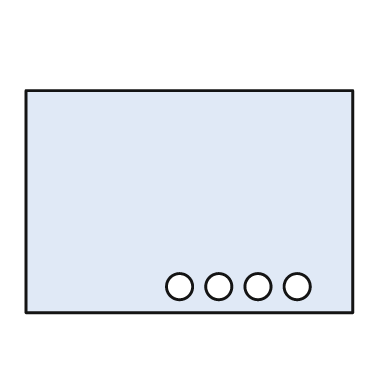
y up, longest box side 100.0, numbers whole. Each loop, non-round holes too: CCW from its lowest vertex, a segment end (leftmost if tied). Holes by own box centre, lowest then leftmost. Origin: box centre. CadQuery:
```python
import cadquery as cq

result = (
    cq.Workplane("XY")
    .moveTo(-50.0, -34.0)
    .lineTo(50.0, -34.0)
    .lineTo(50.0, 34.0)
    .lineTo(-50.0, 34.0)
    .close()
    .moveTo(-3.0, -26.0)
    .circle(4.0)
    .moveTo(9.0, -26.0)
    .circle(4.0)
    .moveTo(21.0, -26.0)
    .circle(4.0)
    .moveTo(33.0, -26.0)
    .circle(4.0)
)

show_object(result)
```